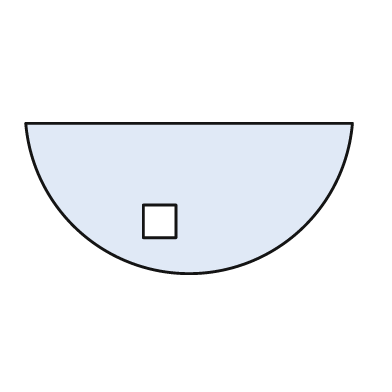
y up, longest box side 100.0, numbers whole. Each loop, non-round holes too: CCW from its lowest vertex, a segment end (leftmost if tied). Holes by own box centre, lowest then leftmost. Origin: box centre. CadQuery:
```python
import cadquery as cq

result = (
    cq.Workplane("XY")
    .moveTo(-50.0, 23.0)
    .threePointArc((0.0, -23.0), (50.0, 23.0))
    .close()
    .moveTo(-14.0, -12.0)
    .lineTo(-4.0, -12.0)
    .lineTo(-4.0, -2.0)
    .lineTo(-14.0, -2.0)
    .close()
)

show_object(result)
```